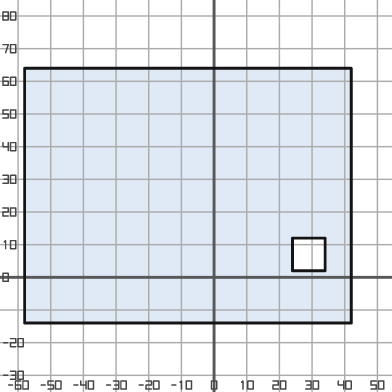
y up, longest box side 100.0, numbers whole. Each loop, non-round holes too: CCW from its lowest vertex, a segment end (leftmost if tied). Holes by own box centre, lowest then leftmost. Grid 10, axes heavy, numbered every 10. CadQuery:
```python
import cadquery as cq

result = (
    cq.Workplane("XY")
    .moveTo(-58.0, -14.0)
    .lineTo(42.0, -14.0)
    .lineTo(42.0, 64.0)
    .lineTo(-58.0, 64.0)
    .close()
    .moveTo(24.0, 2.0)
    .lineTo(34.0, 2.0)
    .lineTo(34.0, 12.0)
    .lineTo(24.0, 12.0)
    .close()
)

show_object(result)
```